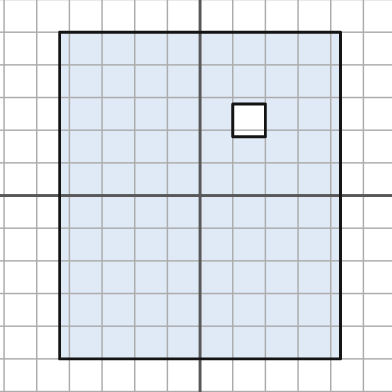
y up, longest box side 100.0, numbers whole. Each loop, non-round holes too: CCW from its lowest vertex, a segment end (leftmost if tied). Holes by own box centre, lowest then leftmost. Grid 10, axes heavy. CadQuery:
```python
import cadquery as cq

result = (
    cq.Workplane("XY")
    .moveTo(-43.0, -50.0)
    .lineTo(43.0, -50.0)
    .lineTo(43.0, 50.0)
    .lineTo(-43.0, 50.0)
    .close()
    .moveTo(10.0, 18.0)
    .lineTo(20.0, 18.0)
    .lineTo(20.0, 28.0)
    .lineTo(10.0, 28.0)
    .close()
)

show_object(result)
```